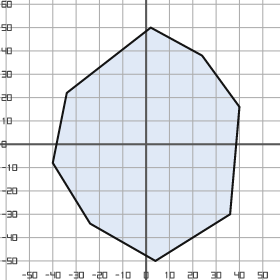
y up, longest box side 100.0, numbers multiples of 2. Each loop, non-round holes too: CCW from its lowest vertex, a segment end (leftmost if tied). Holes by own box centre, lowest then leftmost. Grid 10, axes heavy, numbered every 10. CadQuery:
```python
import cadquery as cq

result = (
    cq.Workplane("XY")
    .moveTo(4.0, -50.0)
    .lineTo(36.0, -30.0)
    .lineTo(40.0, 16.0)
    .lineTo(24.0, 38.0)
    .lineTo(2.0, 50.0)
    .lineTo(-34.0, 22.0)
    .lineTo(-40.0, -8.0)
    .lineTo(-24.0, -34.0)
    .close()
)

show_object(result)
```